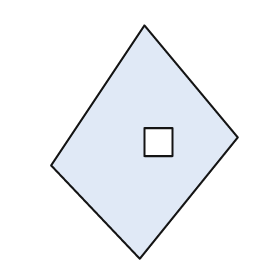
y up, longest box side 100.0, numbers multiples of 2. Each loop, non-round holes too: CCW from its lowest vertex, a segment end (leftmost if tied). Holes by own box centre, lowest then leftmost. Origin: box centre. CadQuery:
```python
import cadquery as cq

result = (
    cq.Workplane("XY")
    .moveTo(-2.0, -50.0)
    .lineTo(40.0, 2.0)
    .lineTo(0.0, 50.0)
    .lineTo(-40.0, -10.0)
    .close()
    .moveTo(0.0, -6.0)
    .lineTo(12.0, -6.0)
    .lineTo(12.0, 6.0)
    .lineTo(0.0, 6.0)
    .close()
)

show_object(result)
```